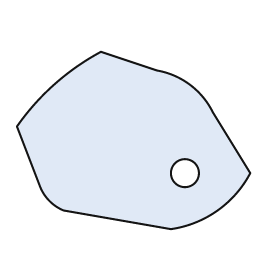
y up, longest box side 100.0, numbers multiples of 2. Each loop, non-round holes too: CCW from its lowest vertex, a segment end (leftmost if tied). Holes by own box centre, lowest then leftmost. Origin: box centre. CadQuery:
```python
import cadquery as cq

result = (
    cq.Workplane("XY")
    .moveTo(16.0, -38.0)
    .threePointArc((36.0, -30.0), (50.0, -14.0))
    .lineTo(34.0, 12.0)
    .threePointArc((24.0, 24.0), (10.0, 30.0))
    .lineTo(-14.0, 38.0)
    .threePointArc((-34.0, 24.0), (-50.0, 6.0))
    .lineTo(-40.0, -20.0)
    .threePointArc((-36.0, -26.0), (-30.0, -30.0))
    .close()
    .moveTo(22.0, -14.0)
    .circle(6.0)
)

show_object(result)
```